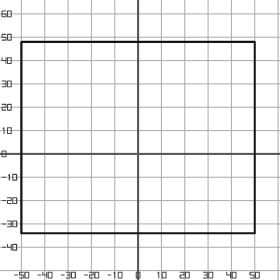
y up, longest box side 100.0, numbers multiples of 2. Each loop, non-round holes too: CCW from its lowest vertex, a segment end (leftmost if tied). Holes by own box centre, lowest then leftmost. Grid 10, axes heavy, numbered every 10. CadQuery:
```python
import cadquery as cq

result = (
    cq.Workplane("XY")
    .moveTo(-50.0, -34.0)
    .lineTo(50.0, -34.0)
    .lineTo(50.0, 48.0)
    .lineTo(-50.0, 48.0)
    .close()
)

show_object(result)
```